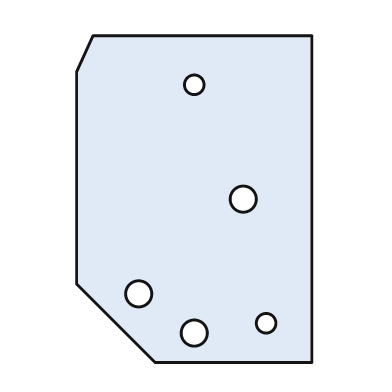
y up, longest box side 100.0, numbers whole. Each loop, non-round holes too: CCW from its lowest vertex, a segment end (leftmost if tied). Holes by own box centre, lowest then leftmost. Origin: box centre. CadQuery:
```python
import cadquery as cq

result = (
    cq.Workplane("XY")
    .moveTo(-12.0, -50.0)
    .lineTo(36.0, -50.0)
    .lineTo(36.0, 50.0)
    .lineTo(-31.0, 50.0)
    .lineTo(-36.0, 39.0)
    .lineTo(-36.0, -26.0)
    .close()
    .moveTo(0.0, -41.0)
    .circle(4.0)
    .moveTo(22.0, -38.0)
    .circle(3.0)
    .moveTo(-17.0, -29.0)
    .circle(4.0)
    .moveTo(15.0, 0.0)
    .circle(4.0)
    .moveTo(0.0, 35.0)
    .circle(3.0)
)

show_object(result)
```